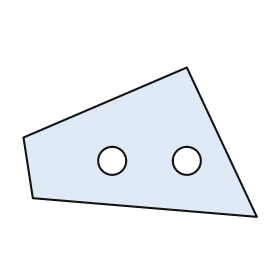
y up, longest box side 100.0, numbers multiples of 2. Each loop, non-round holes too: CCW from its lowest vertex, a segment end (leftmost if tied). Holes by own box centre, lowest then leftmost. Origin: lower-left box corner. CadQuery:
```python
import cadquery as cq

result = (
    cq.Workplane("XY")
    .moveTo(100.0, 0.0)
    .lineTo(70.0, 64.0)
    .lineTo(0.0, 34.0)
    .lineTo(4.0, 8.0)
    .close()
    .moveTo(38.0, 24.0)
    .circle(6.0)
    .moveTo(70.0, 24.0)
    .circle(6.0)
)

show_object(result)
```